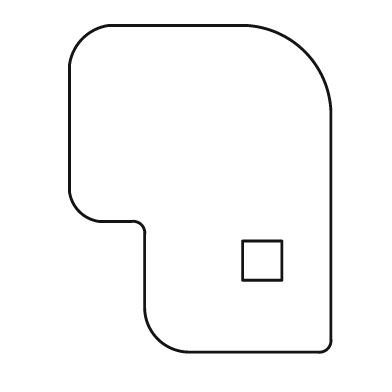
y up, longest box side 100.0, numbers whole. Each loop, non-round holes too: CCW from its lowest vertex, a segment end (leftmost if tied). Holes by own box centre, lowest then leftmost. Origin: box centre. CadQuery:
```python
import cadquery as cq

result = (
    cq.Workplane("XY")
    .moveTo(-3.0, -50.0)
    .lineTo(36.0, -50.0)
    .threePointArc((39.0, -49.0), (40.0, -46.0))
    .lineTo(40.0, 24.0)
    .threePointArc((32.0, 42.0), (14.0, 50.0))
    .lineTo(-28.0, 50.0)
    .threePointArc((-36.0, 46.0), (-40.0, 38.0))
    .lineTo(-40.0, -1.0)
    .threePointArc((-37.0, -7.0), (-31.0, -10.0))
    .lineTo(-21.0, -10.0)
    .threePointArc((-18.0, -11.0), (-17.0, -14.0))
    .lineTo(-17.0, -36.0)
    .threePointArc((-13.0, -46.0), (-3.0, -50.0))
    .close()
    .moveTo(13.0, -28.0)
    .lineTo(25.0, -28.0)
    .lineTo(25.0, -16.0)
    .lineTo(13.0, -16.0)
    .close()
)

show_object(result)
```